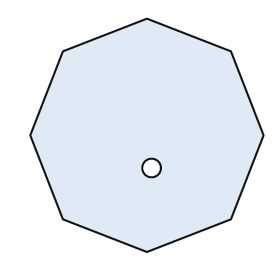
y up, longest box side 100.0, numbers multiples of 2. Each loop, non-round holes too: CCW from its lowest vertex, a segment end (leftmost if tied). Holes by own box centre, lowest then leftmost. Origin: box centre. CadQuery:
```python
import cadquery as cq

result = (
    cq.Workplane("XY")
    .moveTo(0.0, -50.0)
    .lineTo(36.0, -36.0)
    .lineTo(50.0, 0.0)
    .lineTo(36.0, 36.0)
    .lineTo(0.0, 50.0)
    .lineTo(-36.0, 36.0)
    .lineTo(-50.0, 0.0)
    .lineTo(-36.0, -36.0)
    .close()
    .moveTo(2.0, -14.0)
    .circle(4.0)
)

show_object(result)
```